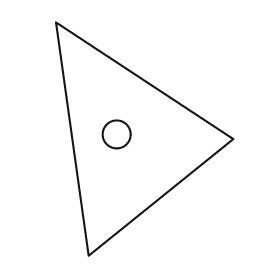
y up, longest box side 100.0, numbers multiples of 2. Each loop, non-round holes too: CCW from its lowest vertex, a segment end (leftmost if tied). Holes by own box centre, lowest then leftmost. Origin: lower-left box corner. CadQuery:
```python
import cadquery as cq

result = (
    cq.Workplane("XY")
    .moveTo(14.0, 0.0)
    .lineTo(76.0, 50.0)
    .lineTo(0.0, 100.0)
    .close()
    .moveTo(26.0, 52.0)
    .circle(6.0)
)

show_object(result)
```